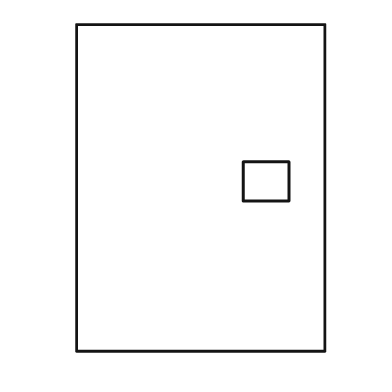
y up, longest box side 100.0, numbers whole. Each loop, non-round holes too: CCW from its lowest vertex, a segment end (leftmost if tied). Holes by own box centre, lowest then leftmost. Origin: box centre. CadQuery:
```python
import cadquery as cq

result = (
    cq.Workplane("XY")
    .moveTo(-38.0, -50.0)
    .lineTo(38.0, -50.0)
    .lineTo(38.0, 50.0)
    .lineTo(-38.0, 50.0)
    .close()
    .moveTo(13.0, -4.0)
    .lineTo(27.0, -4.0)
    .lineTo(27.0, 8.0)
    .lineTo(13.0, 8.0)
    .close()
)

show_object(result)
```